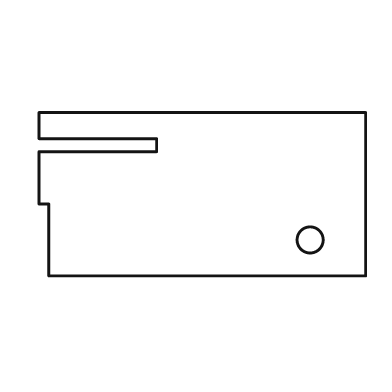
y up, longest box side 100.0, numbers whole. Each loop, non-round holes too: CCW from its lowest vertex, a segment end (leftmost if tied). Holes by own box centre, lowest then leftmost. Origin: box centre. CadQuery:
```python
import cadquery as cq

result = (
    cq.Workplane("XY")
    .moveTo(-47.0, -25.0)
    .lineTo(50.0, -25.0)
    .lineTo(50.0, 25.0)
    .lineTo(-50.0, 25.0)
    .lineTo(-50.0, 17.0)
    .lineTo(-14.0, 17.0)
    .lineTo(-14.0, 13.0)
    .lineTo(-50.0, 13.0)
    .lineTo(-50.0, -3.0)
    .lineTo(-47.0, -3.0)
    .close()
    .moveTo(33.0, -14.0)
    .circle(4.0)
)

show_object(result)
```